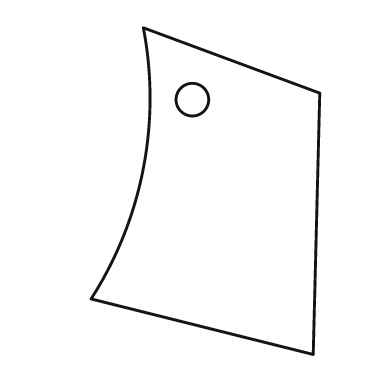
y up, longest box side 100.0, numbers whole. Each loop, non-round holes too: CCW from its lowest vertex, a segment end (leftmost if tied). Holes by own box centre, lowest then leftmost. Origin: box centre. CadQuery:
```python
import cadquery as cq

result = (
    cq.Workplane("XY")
    .moveTo(33.0, -50.0)
    .lineTo(35.0, 30.0)
    .lineTo(-19.0, 50.0)
    .threePointArc((-19.0, 7.0), (-35.0, -33.0))
    .close()
    .moveTo(-4.0, 28.0)
    .circle(5.0)
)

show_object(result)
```